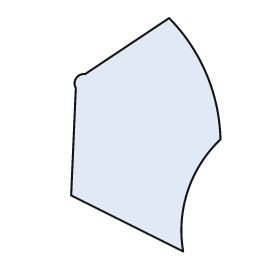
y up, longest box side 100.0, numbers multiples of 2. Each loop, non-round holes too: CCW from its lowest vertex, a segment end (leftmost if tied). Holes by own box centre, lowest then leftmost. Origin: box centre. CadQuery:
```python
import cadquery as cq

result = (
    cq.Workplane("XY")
    .moveTo(16.0, -50.0)
    .threePointArc((18.0, -24.0), (32.0, -2.0))
    .threePointArc((26.0, 26.0), (10.0, 50.0))
    .lineTo(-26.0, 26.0)
    .threePointArc((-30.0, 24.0), (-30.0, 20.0))
    .lineTo(-32.0, -26.0)
    .close()
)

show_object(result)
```